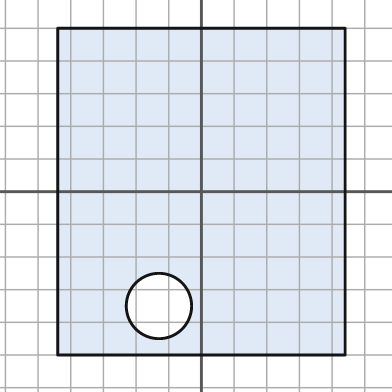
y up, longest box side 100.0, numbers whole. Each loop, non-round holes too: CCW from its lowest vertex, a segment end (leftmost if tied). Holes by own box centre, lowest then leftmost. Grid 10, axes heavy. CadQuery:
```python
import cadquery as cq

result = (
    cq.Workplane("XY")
    .moveTo(-44.0, -50.0)
    .lineTo(44.0, -50.0)
    .lineTo(44.0, 50.0)
    .lineTo(-44.0, 50.0)
    .close()
    .moveTo(-13.0, -35.0)
    .circle(10.0)
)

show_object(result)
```